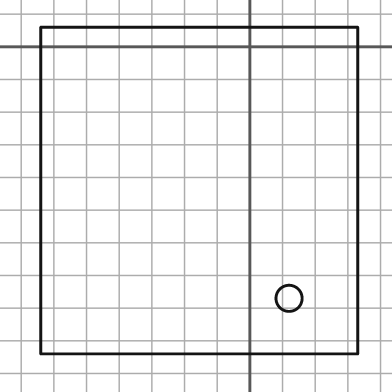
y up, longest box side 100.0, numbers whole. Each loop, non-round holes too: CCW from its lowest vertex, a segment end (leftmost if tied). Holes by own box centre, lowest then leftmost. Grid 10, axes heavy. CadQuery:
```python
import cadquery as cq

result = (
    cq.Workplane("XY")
    .moveTo(-64.0, -94.0)
    .lineTo(33.0, -94.0)
    .lineTo(33.0, 6.0)
    .lineTo(-64.0, 6.0)
    .close()
    .moveTo(12.0, -77.0)
    .circle(4.0)
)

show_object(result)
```